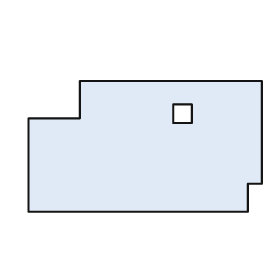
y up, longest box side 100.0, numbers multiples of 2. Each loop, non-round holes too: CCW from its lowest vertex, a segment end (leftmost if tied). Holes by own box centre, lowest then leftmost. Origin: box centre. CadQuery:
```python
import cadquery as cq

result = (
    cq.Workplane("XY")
    .moveTo(-50.0, -28.0)
    .lineTo(44.0, -28.0)
    .lineTo(44.0, -16.0)
    .lineTo(50.0, -16.0)
    .lineTo(50.0, 28.0)
    .lineTo(-28.0, 28.0)
    .lineTo(-28.0, 12.0)
    .lineTo(-50.0, 12.0)
    .close()
    .moveTo(12.0, 10.0)
    .lineTo(20.0, 10.0)
    .lineTo(20.0, 18.0)
    .lineTo(12.0, 18.0)
    .close()
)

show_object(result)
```